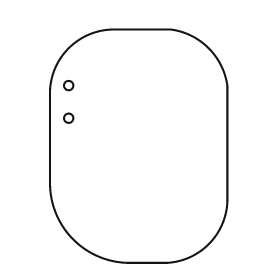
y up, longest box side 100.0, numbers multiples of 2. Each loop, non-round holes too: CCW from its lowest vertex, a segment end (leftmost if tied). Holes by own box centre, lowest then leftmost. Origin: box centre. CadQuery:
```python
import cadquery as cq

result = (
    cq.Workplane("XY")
    .moveTo(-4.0, -50.0)
    .lineTo(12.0, -50.0)
    .threePointArc((30.0, -42.0), (38.0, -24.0))
    .lineTo(38.0, 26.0)
    .threePointArc((30.0, 42.0), (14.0, 50.0))
    .lineTo(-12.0, 50.0)
    .threePointArc((-30.0, 42.0), (-38.0, 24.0))
    .lineTo(-38.0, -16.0)
    .threePointArc((-28.0, -40.0), (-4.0, -50.0))
    .close()
    .moveTo(-30.0, 12.0)
    .circle(2.0)
    .moveTo(-30.0, 26.0)
    .circle(2.0)
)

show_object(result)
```